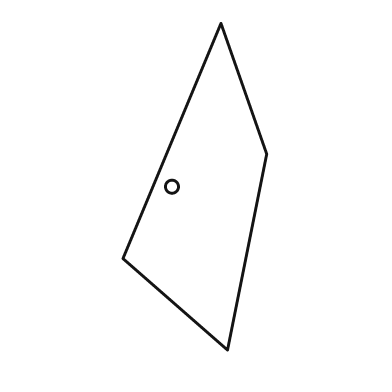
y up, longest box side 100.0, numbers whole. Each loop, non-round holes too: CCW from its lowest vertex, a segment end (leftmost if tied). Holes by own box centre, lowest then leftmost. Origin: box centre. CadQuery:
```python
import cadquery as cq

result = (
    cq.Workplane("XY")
    .moveTo(10.0, -50.0)
    .lineTo(22.0, 10.0)
    .lineTo(8.0, 50.0)
    .lineTo(-22.0, -22.0)
    .close()
    .moveTo(-7.0, 0.0)
    .circle(2.0)
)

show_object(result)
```